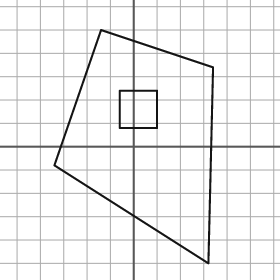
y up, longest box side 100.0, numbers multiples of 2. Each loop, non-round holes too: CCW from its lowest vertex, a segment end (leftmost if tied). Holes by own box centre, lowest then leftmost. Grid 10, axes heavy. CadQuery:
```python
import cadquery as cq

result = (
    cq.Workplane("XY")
    .moveTo(32.0, -50.0)
    .lineTo(34.0, 34.0)
    .lineTo(-14.0, 50.0)
    .lineTo(-34.0, -8.0)
    .close()
    .moveTo(-6.0, 8.0)
    .lineTo(10.0, 8.0)
    .lineTo(10.0, 24.0)
    .lineTo(-6.0, 24.0)
    .close()
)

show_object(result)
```